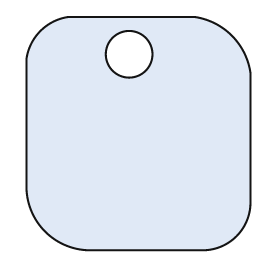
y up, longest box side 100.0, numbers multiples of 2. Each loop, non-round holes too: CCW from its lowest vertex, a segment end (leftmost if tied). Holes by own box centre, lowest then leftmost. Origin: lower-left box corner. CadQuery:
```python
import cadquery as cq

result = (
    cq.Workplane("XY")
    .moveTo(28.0, 0.0)
    .lineTo(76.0, 0.0)
    .threePointArc((90.0, 6.0), (96.0, 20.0))
    .lineTo(96.0, 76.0)
    .threePointArc((88.0, 92.0), (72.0, 100.0))
    .lineTo(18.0, 100.0)
    .threePointArc((6.0, 94.0), (0.0, 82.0))
    .lineTo(0.0, 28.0)
    .threePointArc((8.0, 8.0), (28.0, 0.0))
    .close()
    .moveTo(44.0, 84.0)
    .circle(10.0)
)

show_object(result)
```